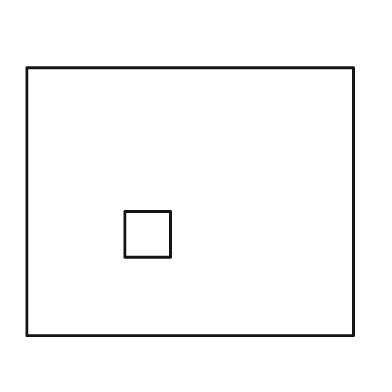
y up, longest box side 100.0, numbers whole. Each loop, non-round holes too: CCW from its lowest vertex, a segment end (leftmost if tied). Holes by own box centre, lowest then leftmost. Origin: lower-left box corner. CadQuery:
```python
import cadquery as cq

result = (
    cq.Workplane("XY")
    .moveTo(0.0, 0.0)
    .lineTo(100.0, 0.0)
    .lineTo(100.0, 82.0)
    .lineTo(0.0, 82.0)
    .close()
    .moveTo(30.0, 24.0)
    .lineTo(44.0, 24.0)
    .lineTo(44.0, 38.0)
    .lineTo(30.0, 38.0)
    .close()
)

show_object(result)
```